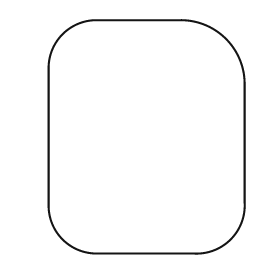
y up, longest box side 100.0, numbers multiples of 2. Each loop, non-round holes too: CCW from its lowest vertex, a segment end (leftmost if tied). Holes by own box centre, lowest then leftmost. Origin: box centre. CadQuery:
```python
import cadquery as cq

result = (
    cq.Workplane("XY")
    .moveTo(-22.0, -50.0)
    .lineTo(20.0, -50.0)
    .threePointArc((36.0, -44.0), (42.0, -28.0))
    .lineTo(42.0, 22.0)
    .threePointArc((34.0, 42.0), (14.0, 50.0))
    .lineTo(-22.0, 50.0)
    .threePointArc((-36.0, 44.0), (-42.0, 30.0))
    .lineTo(-42.0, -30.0)
    .threePointArc((-36.0, -44.0), (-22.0, -50.0))
    .close()
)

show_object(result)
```